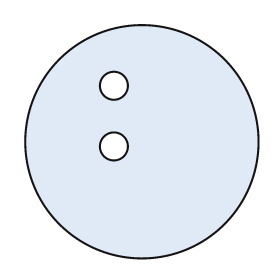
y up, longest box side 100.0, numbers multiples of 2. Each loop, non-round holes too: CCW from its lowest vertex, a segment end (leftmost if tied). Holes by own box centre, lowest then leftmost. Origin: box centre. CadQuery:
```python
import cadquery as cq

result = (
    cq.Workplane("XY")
    .moveTo(0.0, 0.0)
    .circle(50.0)
    .moveTo(-12.0, -2.0)
    .circle(6.0)
    .moveTo(-12.0, 24.0)
    .circle(6.0)
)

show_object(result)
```